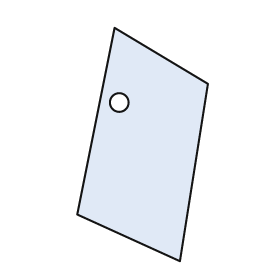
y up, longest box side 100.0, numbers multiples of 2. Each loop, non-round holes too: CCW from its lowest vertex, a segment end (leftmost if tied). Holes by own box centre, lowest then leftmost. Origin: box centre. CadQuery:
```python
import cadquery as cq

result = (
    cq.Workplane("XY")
    .moveTo(16.0, -50.0)
    .lineTo(28.0, 26.0)
    .lineTo(-12.0, 50.0)
    .lineTo(-28.0, -30.0)
    .close()
    .moveTo(-10.0, 18.0)
    .circle(4.0)
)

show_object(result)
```